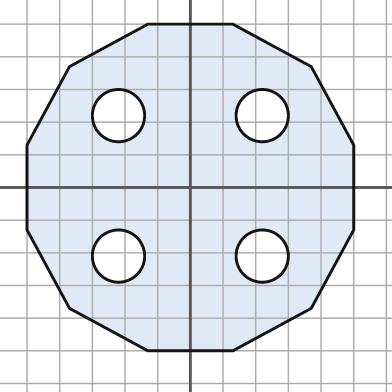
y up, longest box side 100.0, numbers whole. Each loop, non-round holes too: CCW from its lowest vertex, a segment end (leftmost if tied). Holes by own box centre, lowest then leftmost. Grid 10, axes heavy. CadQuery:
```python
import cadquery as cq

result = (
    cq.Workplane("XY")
    .moveTo(-13.0, -50.0)
    .lineTo(13.0, -50.0)
    .lineTo(37.0, -37.0)
    .lineTo(50.0, -13.0)
    .lineTo(50.0, 13.0)
    .lineTo(37.0, 37.0)
    .lineTo(13.0, 50.0)
    .lineTo(-13.0, 50.0)
    .lineTo(-37.0, 37.0)
    .lineTo(-50.0, 13.0)
    .lineTo(-50.0, -13.0)
    .lineTo(-37.0, -37.0)
    .close()
    .moveTo(-22.0, -21.0)
    .circle(8.0)
    .moveTo(22.0, -21.0)
    .circle(8.0)
    .moveTo(-22.0, 22.0)
    .circle(8.0)
    .moveTo(22.0, 22.0)
    .circle(8.0)
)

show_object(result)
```